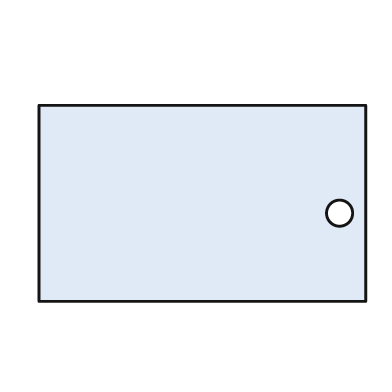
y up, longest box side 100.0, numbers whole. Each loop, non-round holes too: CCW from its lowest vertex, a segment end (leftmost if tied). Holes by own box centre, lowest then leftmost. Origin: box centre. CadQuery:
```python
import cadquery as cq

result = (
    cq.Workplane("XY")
    .moveTo(-50.0, -30.0)
    .lineTo(50.0, -30.0)
    .lineTo(50.0, 30.0)
    .lineTo(-50.0, 30.0)
    .close()
    .moveTo(42.0, -3.0)
    .circle(4.0)
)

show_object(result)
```